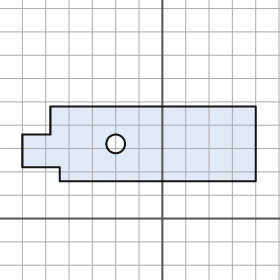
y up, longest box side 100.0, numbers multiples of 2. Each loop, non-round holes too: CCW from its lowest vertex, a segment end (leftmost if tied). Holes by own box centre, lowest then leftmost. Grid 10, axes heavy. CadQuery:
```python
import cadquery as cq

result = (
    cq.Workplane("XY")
    .moveTo(-44.0, 16.0)
    .lineTo(40.0, 16.0)
    .lineTo(40.0, 48.0)
    .lineTo(-48.0, 48.0)
    .lineTo(-48.0, 36.0)
    .lineTo(-60.0, 36.0)
    .lineTo(-60.0, 22.0)
    .lineTo(-44.0, 22.0)
    .close()
    .moveTo(-20.0, 32.0)
    .circle(4.0)
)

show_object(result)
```